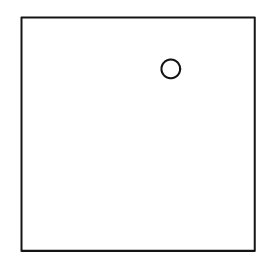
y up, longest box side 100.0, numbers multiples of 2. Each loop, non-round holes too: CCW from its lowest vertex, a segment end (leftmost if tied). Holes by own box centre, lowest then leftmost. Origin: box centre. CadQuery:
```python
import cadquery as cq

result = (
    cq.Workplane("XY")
    .moveTo(-50.0, -50.0)
    .lineTo(50.0, -50.0)
    .lineTo(50.0, 50.0)
    .lineTo(-50.0, 50.0)
    .close()
    .moveTo(14.0, 28.0)
    .circle(4.0)
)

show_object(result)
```